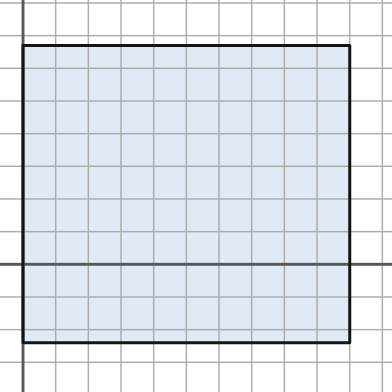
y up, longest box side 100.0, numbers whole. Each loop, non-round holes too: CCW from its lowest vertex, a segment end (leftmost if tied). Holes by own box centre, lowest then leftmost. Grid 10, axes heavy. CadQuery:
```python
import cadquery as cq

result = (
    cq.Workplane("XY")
    .moveTo(0.0, -24.0)
    .lineTo(100.0, -24.0)
    .lineTo(100.0, 67.0)
    .lineTo(0.0, 67.0)
    .close()
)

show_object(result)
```